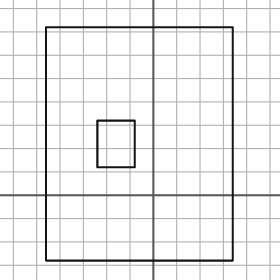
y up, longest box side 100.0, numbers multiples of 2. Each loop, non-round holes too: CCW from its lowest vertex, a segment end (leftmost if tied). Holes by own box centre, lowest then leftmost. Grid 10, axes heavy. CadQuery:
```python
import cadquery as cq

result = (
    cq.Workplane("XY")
    .moveTo(-46.0, -28.0)
    .lineTo(34.0, -28.0)
    .lineTo(34.0, 72.0)
    .lineTo(-46.0, 72.0)
    .close()
    .moveTo(-24.0, 12.0)
    .lineTo(-8.0, 12.0)
    .lineTo(-8.0, 32.0)
    .lineTo(-24.0, 32.0)
    .close()
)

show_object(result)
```